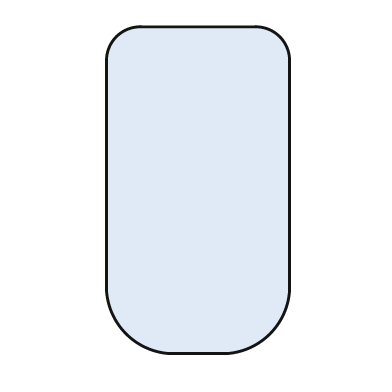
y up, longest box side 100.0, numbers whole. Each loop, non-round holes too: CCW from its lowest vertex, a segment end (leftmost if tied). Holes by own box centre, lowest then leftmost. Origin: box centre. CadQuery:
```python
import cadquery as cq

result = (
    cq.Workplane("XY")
    .moveTo(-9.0, -50.0)
    .lineTo(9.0, -50.0)
    .threePointArc((22.0, -44.0), (28.0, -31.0))
    .lineTo(28.0, 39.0)
    .threePointArc((25.0, 47.0), (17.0, 50.0))
    .lineTo(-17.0, 50.0)
    .threePointArc((-25.0, 47.0), (-28.0, 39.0))
    .lineTo(-28.0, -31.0)
    .threePointArc((-22.0, -44.0), (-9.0, -50.0))
    .close()
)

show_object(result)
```